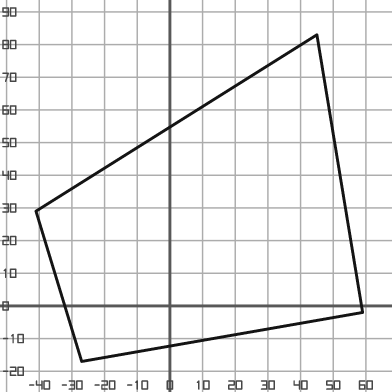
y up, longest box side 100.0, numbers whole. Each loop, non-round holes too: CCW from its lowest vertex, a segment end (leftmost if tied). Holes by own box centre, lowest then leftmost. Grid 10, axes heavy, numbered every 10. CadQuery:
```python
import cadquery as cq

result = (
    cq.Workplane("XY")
    .moveTo(-27.0, -17.0)
    .lineTo(59.0, -2.0)
    .lineTo(45.0, 83.0)
    .lineTo(-41.0, 29.0)
    .close()
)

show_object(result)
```